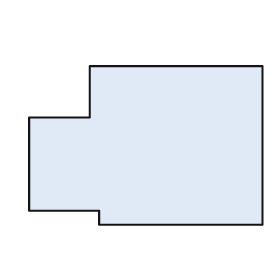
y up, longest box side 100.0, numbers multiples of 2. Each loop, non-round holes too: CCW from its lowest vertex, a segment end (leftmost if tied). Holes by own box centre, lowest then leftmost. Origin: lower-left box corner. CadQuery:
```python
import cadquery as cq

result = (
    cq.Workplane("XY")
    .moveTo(30.0, 0.0)
    .lineTo(100.0, 0.0)
    .lineTo(100.0, 68.0)
    .lineTo(26.0, 68.0)
    .lineTo(26.0, 46.0)
    .lineTo(0.0, 46.0)
    .lineTo(0.0, 6.0)
    .lineTo(30.0, 6.0)
    .close()
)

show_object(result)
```